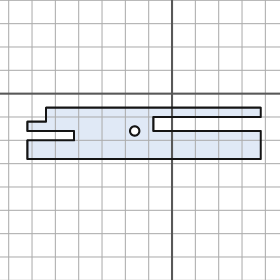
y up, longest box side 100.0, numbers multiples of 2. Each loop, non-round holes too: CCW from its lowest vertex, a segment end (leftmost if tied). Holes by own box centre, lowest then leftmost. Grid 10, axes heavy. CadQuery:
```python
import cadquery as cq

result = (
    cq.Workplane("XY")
    .moveTo(-62.0, -28.0)
    .lineTo(38.0, -28.0)
    .lineTo(38.0, -16.0)
    .lineTo(-8.0, -16.0)
    .lineTo(-8.0, -10.0)
    .lineTo(38.0, -10.0)
    .lineTo(38.0, -6.0)
    .lineTo(-54.0, -6.0)
    .lineTo(-54.0, -12.0)
    .lineTo(-62.0, -12.0)
    .lineTo(-62.0, -16.0)
    .lineTo(-42.0, -16.0)
    .lineTo(-42.0, -20.0)
    .lineTo(-62.0, -20.0)
    .close()
    .moveTo(-16.0, -16.0)
    .circle(2.0)
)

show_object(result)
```